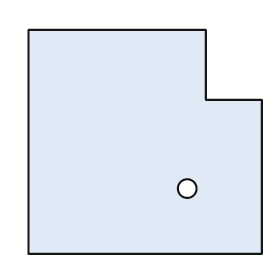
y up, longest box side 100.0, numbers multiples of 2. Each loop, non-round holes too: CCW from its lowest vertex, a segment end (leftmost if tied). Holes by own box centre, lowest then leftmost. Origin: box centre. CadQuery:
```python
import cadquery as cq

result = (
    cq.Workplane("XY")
    .moveTo(-50.0, -48.0)
    .lineTo(50.0, -48.0)
    .lineTo(50.0, 18.0)
    .lineTo(26.0, 18.0)
    .lineTo(26.0, 48.0)
    .lineTo(-50.0, 48.0)
    .close()
    .moveTo(18.0, -20.0)
    .circle(4.0)
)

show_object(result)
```